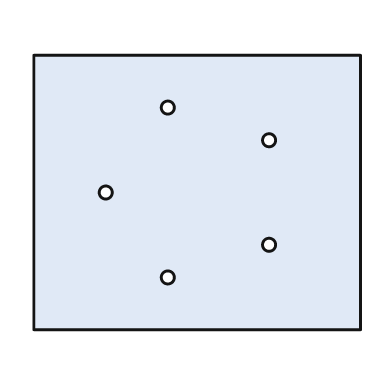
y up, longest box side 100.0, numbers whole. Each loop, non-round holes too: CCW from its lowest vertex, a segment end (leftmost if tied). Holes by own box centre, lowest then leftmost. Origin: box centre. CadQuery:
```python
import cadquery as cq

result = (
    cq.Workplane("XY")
    .moveTo(-50.0, -42.0)
    .lineTo(50.0, -42.0)
    .lineTo(50.0, 42.0)
    .lineTo(-50.0, 42.0)
    .close()
    .moveTo(-9.0, -26.0)
    .circle(2.0)
    .moveTo(22.0, -16.0)
    .circle(2.0)
    .moveTo(-28.0, 0.0)
    .circle(2.0)
    .moveTo(22.0, 16.0)
    .circle(2.0)
    .moveTo(-9.0, 26.0)
    .circle(2.0)
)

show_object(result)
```